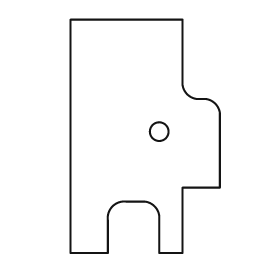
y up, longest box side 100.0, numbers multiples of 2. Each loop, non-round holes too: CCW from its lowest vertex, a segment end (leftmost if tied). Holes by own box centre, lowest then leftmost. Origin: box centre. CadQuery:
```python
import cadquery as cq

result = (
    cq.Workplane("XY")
    .moveTo(-32.0, -50.0)
    .lineTo(-16.0, -50.0)
    .lineTo(-16.0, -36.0)
    .threePointArc((-14.0, -30.0), (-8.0, -28.0))
    .lineTo(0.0, -28.0)
    .threePointArc((4.0, -30.0), (6.0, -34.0))
    .lineTo(6.0, -50.0)
    .lineTo(16.0, -50.0)
    .lineTo(16.0, -22.0)
    .lineTo(32.0, -22.0)
    .lineTo(32.0, 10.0)
    .threePointArc((30.0, 14.0), (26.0, 16.0))
    .lineTo(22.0, 16.0)
    .threePointArc((18.0, 18.0), (16.0, 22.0))
    .lineTo(16.0, 50.0)
    .lineTo(-32.0, 50.0)
    .close()
    .moveTo(6.0, 2.0)
    .circle(4.0)
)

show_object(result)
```